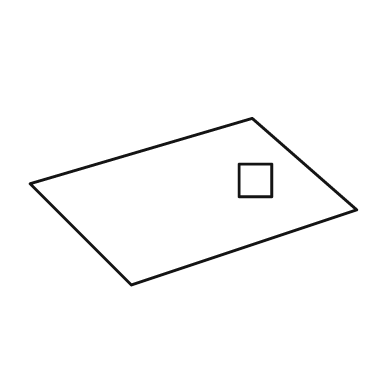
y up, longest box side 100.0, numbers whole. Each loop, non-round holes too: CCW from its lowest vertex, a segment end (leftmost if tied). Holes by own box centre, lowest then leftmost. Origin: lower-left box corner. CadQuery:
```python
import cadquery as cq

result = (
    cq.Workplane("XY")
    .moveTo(31.0, 0.0)
    .lineTo(100.0, 23.0)
    .lineTo(68.0, 51.0)
    .lineTo(0.0, 31.0)
    .close()
    .moveTo(64.0, 27.0)
    .lineTo(74.0, 27.0)
    .lineTo(74.0, 37.0)
    .lineTo(64.0, 37.0)
    .close()
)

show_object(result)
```